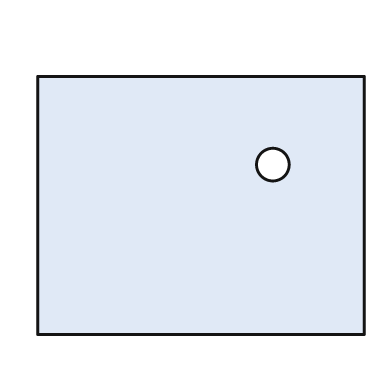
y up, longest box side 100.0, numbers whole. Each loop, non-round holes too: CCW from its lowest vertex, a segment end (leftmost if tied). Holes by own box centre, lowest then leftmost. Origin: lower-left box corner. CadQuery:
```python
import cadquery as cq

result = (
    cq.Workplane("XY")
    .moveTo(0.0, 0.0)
    .lineTo(100.0, 0.0)
    .lineTo(100.0, 79.0)
    .lineTo(0.0, 79.0)
    .close()
    .moveTo(72.0, 52.0)
    .circle(5.0)
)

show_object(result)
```